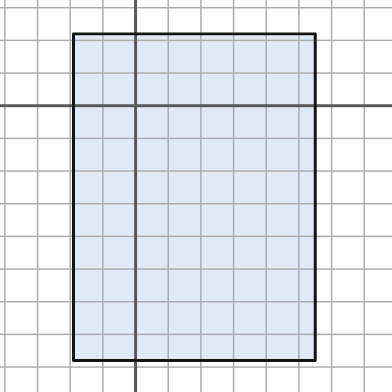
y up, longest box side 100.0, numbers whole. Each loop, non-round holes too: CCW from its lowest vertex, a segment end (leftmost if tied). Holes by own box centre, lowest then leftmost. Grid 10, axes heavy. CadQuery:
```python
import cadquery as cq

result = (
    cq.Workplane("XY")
    .moveTo(-19.0, -78.0)
    .lineTo(55.0, -78.0)
    .lineTo(55.0, 22.0)
    .lineTo(-19.0, 22.0)
    .close()
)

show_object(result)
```